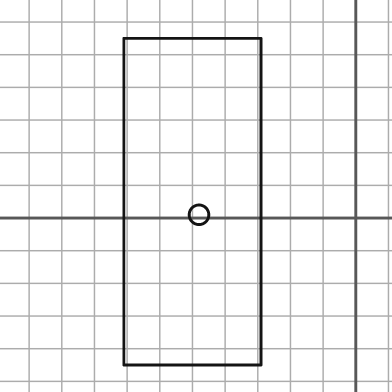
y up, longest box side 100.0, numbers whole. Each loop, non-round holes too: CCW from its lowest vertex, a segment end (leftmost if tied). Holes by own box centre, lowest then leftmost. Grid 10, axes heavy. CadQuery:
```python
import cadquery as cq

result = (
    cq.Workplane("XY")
    .moveTo(-71.0, -45.0)
    .lineTo(-29.0, -45.0)
    .lineTo(-29.0, 55.0)
    .lineTo(-71.0, 55.0)
    .close()
    .moveTo(-48.0, 1.0)
    .circle(3.0)
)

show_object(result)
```